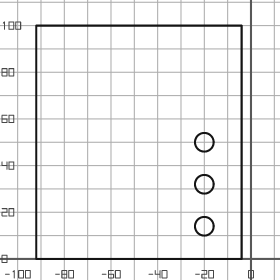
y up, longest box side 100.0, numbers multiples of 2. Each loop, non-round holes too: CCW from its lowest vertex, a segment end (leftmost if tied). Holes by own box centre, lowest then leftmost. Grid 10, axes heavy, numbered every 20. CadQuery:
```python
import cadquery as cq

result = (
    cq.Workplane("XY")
    .moveTo(-92.0, 0.0)
    .lineTo(-4.0, 0.0)
    .lineTo(-4.0, 100.0)
    .lineTo(-92.0, 100.0)
    .close()
    .moveTo(-20.0, 14.0)
    .circle(4.0)
    .moveTo(-20.0, 32.0)
    .circle(4.0)
    .moveTo(-20.0, 50.0)
    .circle(4.0)
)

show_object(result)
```